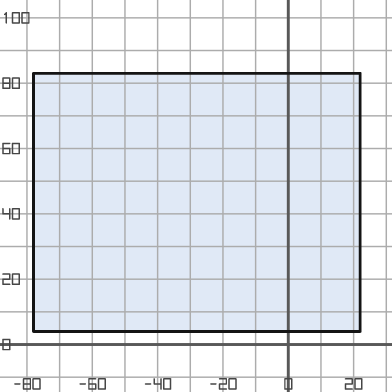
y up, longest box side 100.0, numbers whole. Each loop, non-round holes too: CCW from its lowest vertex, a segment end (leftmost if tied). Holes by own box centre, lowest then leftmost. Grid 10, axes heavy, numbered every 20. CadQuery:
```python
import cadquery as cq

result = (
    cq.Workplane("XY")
    .moveTo(-78.0, 4.0)
    .lineTo(22.0, 4.0)
    .lineTo(22.0, 83.0)
    .lineTo(-78.0, 83.0)
    .close()
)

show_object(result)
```